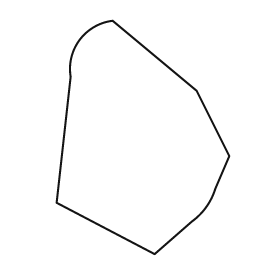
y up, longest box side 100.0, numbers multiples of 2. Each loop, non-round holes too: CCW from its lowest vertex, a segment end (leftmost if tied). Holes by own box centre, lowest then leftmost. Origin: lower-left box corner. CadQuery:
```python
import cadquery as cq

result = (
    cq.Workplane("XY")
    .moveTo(42.0, 0.0)
    .lineTo(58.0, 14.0)
    .threePointArc((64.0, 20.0), (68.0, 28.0))
    .lineTo(74.0, 42.0)
    .lineTo(60.0, 70.0)
    .lineTo(24.0, 100.0)
    .threePointArc((10.0, 92.0), (6.0, 76.0))
    .lineTo(0.0, 22.0)
    .close()
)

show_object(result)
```